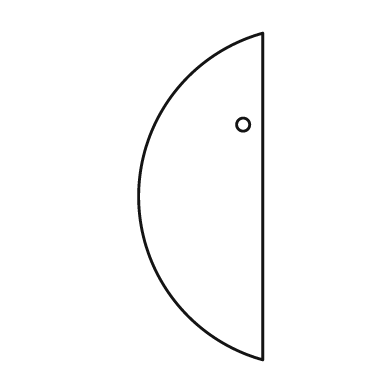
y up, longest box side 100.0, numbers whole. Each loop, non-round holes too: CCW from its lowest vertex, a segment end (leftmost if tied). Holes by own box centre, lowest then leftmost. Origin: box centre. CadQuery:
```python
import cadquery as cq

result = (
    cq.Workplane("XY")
    .moveTo(19.0, -50.0)
    .lineTo(19.0, 50.0)
    .threePointArc((-19.0, 0.0), (19.0, -50.0))
    .close()
    .moveTo(13.0, 22.0)
    .circle(2.0)
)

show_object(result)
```